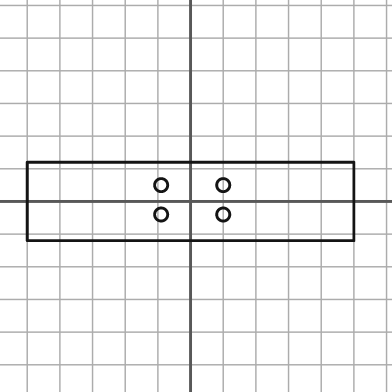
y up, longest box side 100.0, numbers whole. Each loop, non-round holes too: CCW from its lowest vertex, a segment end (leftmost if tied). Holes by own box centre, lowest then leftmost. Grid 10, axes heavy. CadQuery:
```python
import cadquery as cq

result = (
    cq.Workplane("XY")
    .moveTo(-50.0, -12.0)
    .lineTo(50.0, -12.0)
    .lineTo(50.0, 12.0)
    .lineTo(-50.0, 12.0)
    .close()
    .moveTo(-9.0, -4.0)
    .circle(2.0)
    .moveTo(10.0, -4.0)
    .circle(2.0)
    .moveTo(-9.0, 5.0)
    .circle(2.0)
    .moveTo(10.0, 5.0)
    .circle(2.0)
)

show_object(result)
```